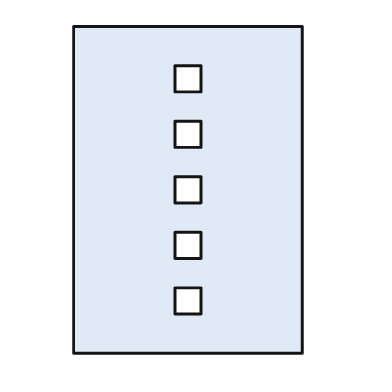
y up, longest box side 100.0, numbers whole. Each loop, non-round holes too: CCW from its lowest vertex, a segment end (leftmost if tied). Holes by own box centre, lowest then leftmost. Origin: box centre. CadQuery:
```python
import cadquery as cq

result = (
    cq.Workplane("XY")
    .moveTo(-35.0, -50.0)
    .lineTo(35.0, -50.0)
    .lineTo(35.0, 50.0)
    .lineTo(-35.0, 50.0)
    .close()
    .moveTo(-4.0, -38.0)
    .lineTo(4.0, -38.0)
    .lineTo(4.0, -30.0)
    .lineTo(-4.0, -30.0)
    .close()
    .moveTo(-4.0, -21.0)
    .lineTo(4.0, -21.0)
    .lineTo(4.0, -13.0)
    .lineTo(-4.0, -13.0)
    .close()
    .moveTo(-4.0, -4.0)
    .lineTo(4.0, -4.0)
    .lineTo(4.0, 4.0)
    .lineTo(-4.0, 4.0)
    .close()
    .moveTo(-4.0, 13.0)
    .lineTo(4.0, 13.0)
    .lineTo(4.0, 21.0)
    .lineTo(-4.0, 21.0)
    .close()
    .moveTo(-4.0, 30.0)
    .lineTo(4.0, 30.0)
    .lineTo(4.0, 38.0)
    .lineTo(-4.0, 38.0)
    .close()
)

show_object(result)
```